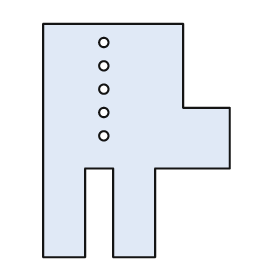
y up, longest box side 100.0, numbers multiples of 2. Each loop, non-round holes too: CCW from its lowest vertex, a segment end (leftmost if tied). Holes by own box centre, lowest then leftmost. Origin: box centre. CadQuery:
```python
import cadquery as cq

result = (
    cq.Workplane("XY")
    .moveTo(-40.0, -50.0)
    .lineTo(-22.0, -50.0)
    .lineTo(-22.0, -12.0)
    .lineTo(-10.0, -12.0)
    .lineTo(-10.0, -50.0)
    .lineTo(8.0, -50.0)
    .lineTo(8.0, -12.0)
    .lineTo(40.0, -12.0)
    .lineTo(40.0, 14.0)
    .lineTo(20.0, 14.0)
    .lineTo(20.0, 50.0)
    .lineTo(-40.0, 50.0)
    .close()
    .moveTo(-14.0, 2.0)
    .circle(2.0)
    .moveTo(-14.0, 12.0)
    .circle(2.0)
    .moveTo(-14.0, 22.0)
    .circle(2.0)
    .moveTo(-14.0, 32.0)
    .circle(2.0)
    .moveTo(-14.0, 42.0)
    .circle(2.0)
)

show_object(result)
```